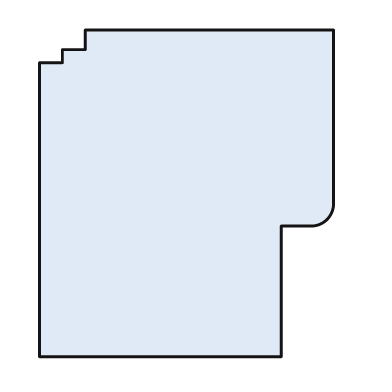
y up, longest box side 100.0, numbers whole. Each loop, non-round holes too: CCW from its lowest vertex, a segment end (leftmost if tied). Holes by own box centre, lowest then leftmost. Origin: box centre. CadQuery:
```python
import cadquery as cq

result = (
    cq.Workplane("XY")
    .moveTo(-45.0, -50.0)
    .lineTo(29.0, -50.0)
    .lineTo(29.0, -10.0)
    .lineTo(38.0, -10.0)
    .threePointArc((43.0, -8.0), (45.0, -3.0))
    .lineTo(45.0, 50.0)
    .lineTo(-31.0, 50.0)
    .lineTo(-31.0, 44.0)
    .lineTo(-38.0, 44.0)
    .lineTo(-38.0, 40.0)
    .lineTo(-45.0, 40.0)
    .close()
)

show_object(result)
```